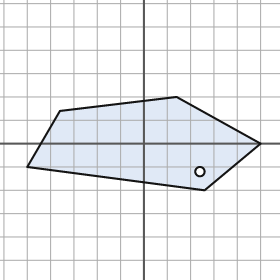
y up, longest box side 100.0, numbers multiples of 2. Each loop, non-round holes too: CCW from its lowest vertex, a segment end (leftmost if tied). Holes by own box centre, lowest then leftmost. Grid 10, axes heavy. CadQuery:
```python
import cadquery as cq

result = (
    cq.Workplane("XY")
    .moveTo(26.0, -20.0)
    .lineTo(50.0, 0.0)
    .lineTo(14.0, 20.0)
    .lineTo(-36.0, 14.0)
    .lineTo(-50.0, -10.0)
    .close()
    .moveTo(24.0, -12.0)
    .circle(2.0)
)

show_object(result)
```